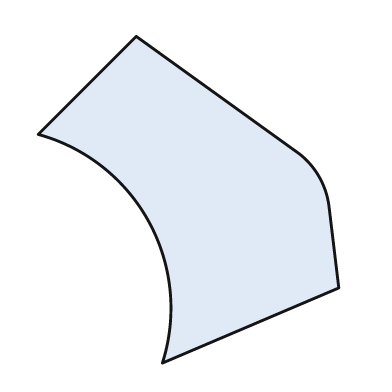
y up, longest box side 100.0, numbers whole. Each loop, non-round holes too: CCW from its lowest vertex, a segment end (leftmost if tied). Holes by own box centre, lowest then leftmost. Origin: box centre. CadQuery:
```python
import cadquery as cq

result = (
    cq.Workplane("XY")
    .moveTo(-8.0, -50.0)
    .lineTo(46.0, -27.0)
    .lineTo(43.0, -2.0)
    .threePointArc((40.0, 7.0), (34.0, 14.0))
    .lineTo(-16.0, 50.0)
    .lineTo(-46.0, 20.0)
    .threePointArc((-12.0, -7.0), (-8.0, -50.0))
    .close()
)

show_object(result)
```